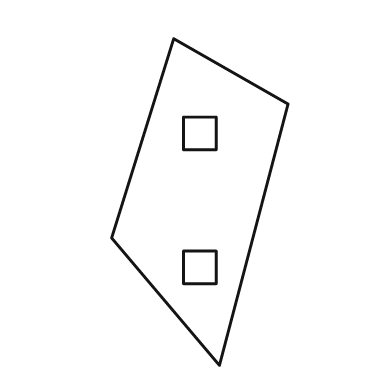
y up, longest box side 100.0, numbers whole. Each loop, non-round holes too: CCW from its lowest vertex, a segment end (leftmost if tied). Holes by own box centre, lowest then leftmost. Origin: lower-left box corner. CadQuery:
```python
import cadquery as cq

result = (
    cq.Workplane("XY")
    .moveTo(33.0, 0.0)
    .lineTo(54.0, 80.0)
    .lineTo(19.0, 100.0)
    .lineTo(0.0, 39.0)
    .close()
    .moveTo(22.0, 25.0)
    .lineTo(32.0, 25.0)
    .lineTo(32.0, 35.0)
    .lineTo(22.0, 35.0)
    .close()
    .moveTo(22.0, 66.0)
    .lineTo(32.0, 66.0)
    .lineTo(32.0, 76.0)
    .lineTo(22.0, 76.0)
    .close()
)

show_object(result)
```